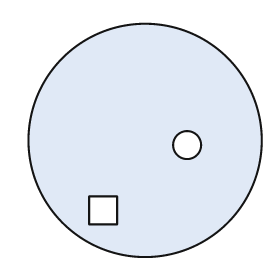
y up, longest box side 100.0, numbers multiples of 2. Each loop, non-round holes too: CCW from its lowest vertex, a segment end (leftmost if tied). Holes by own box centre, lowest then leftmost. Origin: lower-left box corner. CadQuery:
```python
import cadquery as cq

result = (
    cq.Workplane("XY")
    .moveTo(50.0, 50.0)
    .circle(50.0)
    .moveTo(26.0, 14.0)
    .lineTo(38.0, 14.0)
    .lineTo(38.0, 26.0)
    .lineTo(26.0, 26.0)
    .close()
    .moveTo(68.0, 48.0)
    .circle(6.0)
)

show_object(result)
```